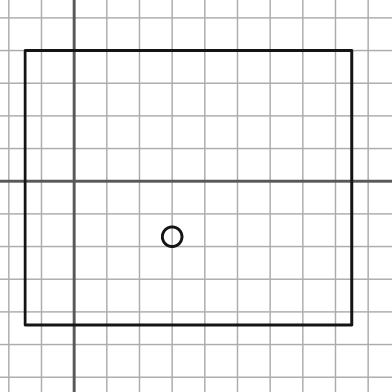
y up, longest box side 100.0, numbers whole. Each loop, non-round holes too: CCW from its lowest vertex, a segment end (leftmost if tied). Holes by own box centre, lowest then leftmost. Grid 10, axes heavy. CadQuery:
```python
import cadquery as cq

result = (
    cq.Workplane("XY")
    .moveTo(-15.0, -44.0)
    .lineTo(85.0, -44.0)
    .lineTo(85.0, 40.0)
    .lineTo(-15.0, 40.0)
    .close()
    .moveTo(30.0, -17.0)
    .circle(3.0)
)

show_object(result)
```